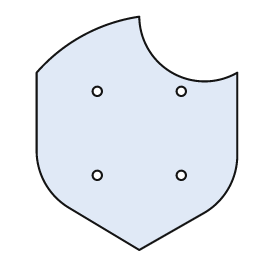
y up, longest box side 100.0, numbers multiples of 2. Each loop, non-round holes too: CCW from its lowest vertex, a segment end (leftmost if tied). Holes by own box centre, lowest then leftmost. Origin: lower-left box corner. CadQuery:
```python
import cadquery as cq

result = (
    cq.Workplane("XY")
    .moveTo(44.0, 0.0)
    .lineTo(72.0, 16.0)
    .threePointArc((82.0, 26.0), (86.0, 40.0))
    .lineTo(86.0, 76.0)
    .threePointArc((58.0, 76.0), (44.0, 100.0))
    .threePointArc((20.0, 92.0), (0.0, 76.0))
    .lineTo(0.0, 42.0)
    .threePointArc((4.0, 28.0), (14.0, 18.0))
    .close()
    .moveTo(26.0, 32.0)
    .circle(2.0)
    .moveTo(62.0, 32.0)
    .circle(2.0)
    .moveTo(26.0, 68.0)
    .circle(2.0)
    .moveTo(62.0, 68.0)
    .circle(2.0)
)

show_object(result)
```